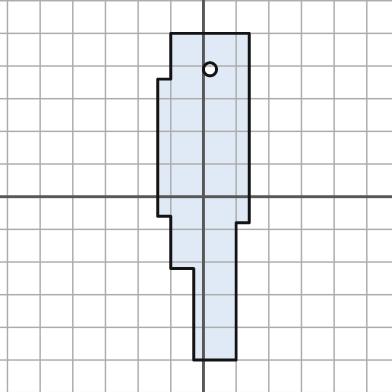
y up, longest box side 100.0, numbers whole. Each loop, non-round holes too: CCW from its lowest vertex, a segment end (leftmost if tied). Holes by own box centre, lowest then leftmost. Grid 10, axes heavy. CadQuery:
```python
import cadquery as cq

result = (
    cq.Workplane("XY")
    .moveTo(-3.0, -50.0)
    .lineTo(10.0, -50.0)
    .lineTo(10.0, -8.0)
    .lineTo(14.0, -8.0)
    .lineTo(14.0, 50.0)
    .lineTo(-10.0, 50.0)
    .lineTo(-10.0, 36.0)
    .lineTo(-14.0, 36.0)
    .lineTo(-14.0, -6.0)
    .lineTo(-10.0, -6.0)
    .lineTo(-10.0, -22.0)
    .lineTo(-3.0, -22.0)
    .close()
    .moveTo(2.0, 39.0)
    .circle(2.0)
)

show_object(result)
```